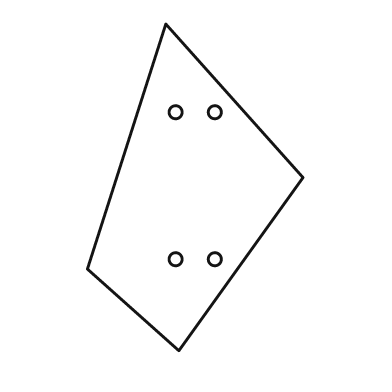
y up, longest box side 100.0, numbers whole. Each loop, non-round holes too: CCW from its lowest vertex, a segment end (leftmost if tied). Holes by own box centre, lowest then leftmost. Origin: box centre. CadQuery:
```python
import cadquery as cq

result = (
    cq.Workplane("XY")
    .moveTo(-5.0, -50.0)
    .lineTo(33.0, 3.0)
    .lineTo(-9.0, 50.0)
    .lineTo(-33.0, -25.0)
    .close()
    .moveTo(-6.0, -22.0)
    .circle(2.0)
    .moveTo(6.0, -22.0)
    .circle(2.0)
    .moveTo(-6.0, 23.0)
    .circle(2.0)
    .moveTo(6.0, 23.0)
    .circle(2.0)
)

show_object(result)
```